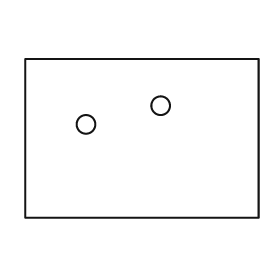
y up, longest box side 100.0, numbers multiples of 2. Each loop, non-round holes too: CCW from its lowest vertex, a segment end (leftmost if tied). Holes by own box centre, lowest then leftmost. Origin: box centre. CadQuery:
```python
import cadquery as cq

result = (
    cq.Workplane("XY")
    .moveTo(-50.0, -34.0)
    .lineTo(50.0, -34.0)
    .lineTo(50.0, 34.0)
    .lineTo(-50.0, 34.0)
    .close()
    .moveTo(-24.0, 6.0)
    .circle(4.0)
    .moveTo(8.0, 14.0)
    .circle(4.0)
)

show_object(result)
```